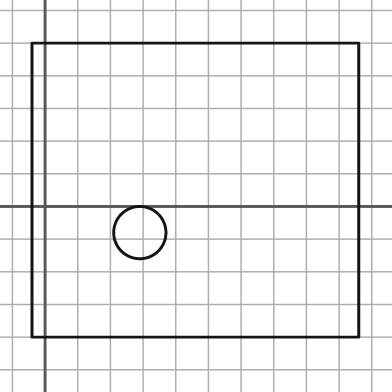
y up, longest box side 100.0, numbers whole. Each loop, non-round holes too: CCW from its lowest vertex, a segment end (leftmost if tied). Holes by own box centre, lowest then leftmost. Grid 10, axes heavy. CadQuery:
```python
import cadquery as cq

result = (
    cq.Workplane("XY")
    .moveTo(-4.0, -40.0)
    .lineTo(96.0, -40.0)
    .lineTo(96.0, 50.0)
    .lineTo(-4.0, 50.0)
    .close()
    .moveTo(29.0, -8.0)
    .circle(8.0)
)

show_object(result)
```